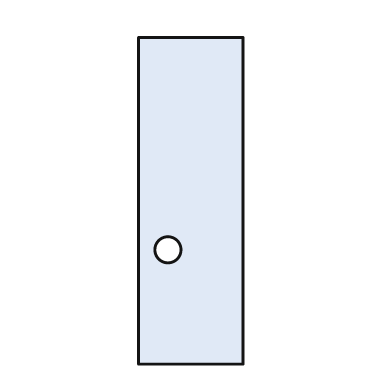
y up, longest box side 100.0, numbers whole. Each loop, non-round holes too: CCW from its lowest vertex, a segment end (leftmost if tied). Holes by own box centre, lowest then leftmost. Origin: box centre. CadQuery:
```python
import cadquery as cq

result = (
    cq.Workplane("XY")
    .moveTo(-16.0, -50.0)
    .lineTo(16.0, -50.0)
    .lineTo(16.0, 50.0)
    .lineTo(-16.0, 50.0)
    .close()
    .moveTo(-7.0, -15.0)
    .circle(4.0)
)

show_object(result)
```